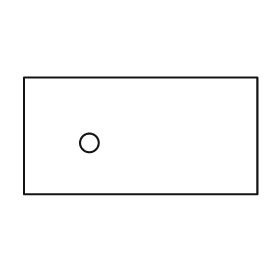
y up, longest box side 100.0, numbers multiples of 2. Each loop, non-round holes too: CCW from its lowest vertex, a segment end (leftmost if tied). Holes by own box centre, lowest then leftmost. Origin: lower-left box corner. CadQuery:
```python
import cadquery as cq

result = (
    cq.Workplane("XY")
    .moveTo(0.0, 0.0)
    .lineTo(100.0, 0.0)
    .lineTo(100.0, 50.0)
    .lineTo(0.0, 50.0)
    .close()
    .moveTo(28.0, 22.0)
    .circle(4.0)
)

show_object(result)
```